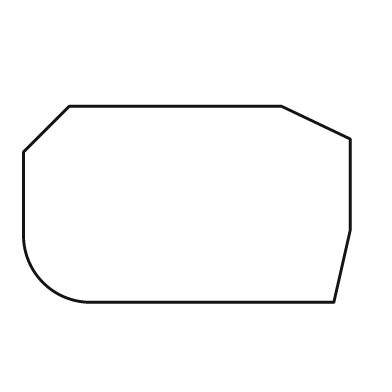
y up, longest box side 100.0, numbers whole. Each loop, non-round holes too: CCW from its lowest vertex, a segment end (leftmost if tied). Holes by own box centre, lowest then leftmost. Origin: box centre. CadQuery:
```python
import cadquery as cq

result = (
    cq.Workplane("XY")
    .moveTo(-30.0, -30.0)
    .lineTo(45.0, -30.0)
    .lineTo(50.0, -8.0)
    .lineTo(50.0, 20.0)
    .lineTo(29.0, 30.0)
    .lineTo(-36.0, 30.0)
    .lineTo(-50.0, 16.0)
    .lineTo(-50.0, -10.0)
    .threePointArc((-44.0, -24.0), (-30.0, -30.0))
    .close()
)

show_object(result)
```